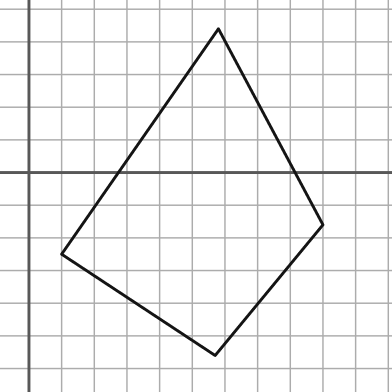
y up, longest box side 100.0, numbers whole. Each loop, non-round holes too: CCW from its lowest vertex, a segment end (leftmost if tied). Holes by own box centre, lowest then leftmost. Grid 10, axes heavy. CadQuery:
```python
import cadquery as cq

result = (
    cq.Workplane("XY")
    .moveTo(57.0, -56.0)
    .lineTo(90.0, -16.0)
    .lineTo(58.0, 44.0)
    .lineTo(10.0, -25.0)
    .close()
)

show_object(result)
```